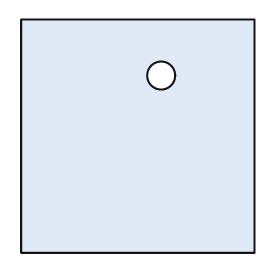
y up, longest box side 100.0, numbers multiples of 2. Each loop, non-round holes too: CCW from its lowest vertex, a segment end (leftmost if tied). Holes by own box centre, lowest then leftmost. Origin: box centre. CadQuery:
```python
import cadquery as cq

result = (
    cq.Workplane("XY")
    .moveTo(-50.0, -50.0)
    .lineTo(50.0, -50.0)
    .lineTo(50.0, 50.0)
    .lineTo(-50.0, 50.0)
    .close()
    .moveTo(10.0, 26.0)
    .circle(6.0)
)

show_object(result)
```